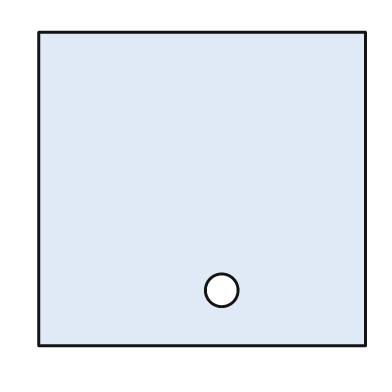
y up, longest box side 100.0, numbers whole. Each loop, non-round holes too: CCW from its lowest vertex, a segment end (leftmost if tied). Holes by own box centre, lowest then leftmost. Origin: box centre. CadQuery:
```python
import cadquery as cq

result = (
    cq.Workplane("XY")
    .moveTo(-50.0, -48.0)
    .lineTo(50.0, -48.0)
    .lineTo(50.0, 48.0)
    .lineTo(-50.0, 48.0)
    .close()
    .moveTo(6.0, -31.0)
    .circle(5.0)
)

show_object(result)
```